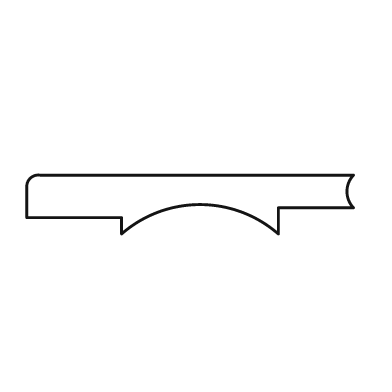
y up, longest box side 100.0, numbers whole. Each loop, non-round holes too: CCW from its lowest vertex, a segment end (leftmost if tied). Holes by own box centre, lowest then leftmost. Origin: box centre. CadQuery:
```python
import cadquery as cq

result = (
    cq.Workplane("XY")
    .moveTo(-21.0, -9.0)
    .threePointArc((3.0, 0.0), (27.0, -9.0))
    .lineTo(27.0, -1.0)
    .lineTo(50.0, -1.0)
    .threePointArc((48.0, 4.0), (50.0, 9.0))
    .lineTo(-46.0, 9.0)
    .threePointArc((-49.0, 8.0), (-50.0, 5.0))
    .lineTo(-50.0, -4.0)
    .lineTo(-21.0, -4.0)
    .close()
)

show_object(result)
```